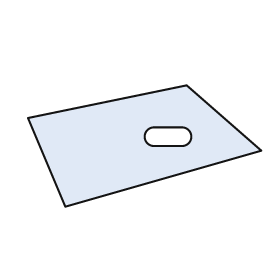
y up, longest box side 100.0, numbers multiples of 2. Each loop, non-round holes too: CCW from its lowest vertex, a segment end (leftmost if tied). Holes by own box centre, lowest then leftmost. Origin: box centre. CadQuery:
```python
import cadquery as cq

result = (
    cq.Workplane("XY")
    .moveTo(-34.0, -26.0)
    .lineTo(50.0, -2.0)
    .lineTo(18.0, 26.0)
    .lineTo(-50.0, 12.0)
    .close()
    .moveTo(4.0, 0.0)
    .lineTo(16.0, 0.0)
    .threePointArc((20.0, 4.0), (16.0, 8.0))
    .lineTo(4.0, 8.0)
    .threePointArc((0.0, 4.0), (4.0, 0.0))
    .close()
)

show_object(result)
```